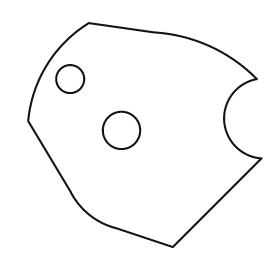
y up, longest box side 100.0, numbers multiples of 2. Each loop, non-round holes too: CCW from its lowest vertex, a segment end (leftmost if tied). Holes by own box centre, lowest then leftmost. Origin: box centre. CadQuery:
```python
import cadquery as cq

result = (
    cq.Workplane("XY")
    .moveTo(12.0, -48.0)
    .lineTo(50.0, -10.0)
    .threePointArc((34.0, 6.0), (48.0, 24.0))
    .threePointArc((28.0, 38.0), (4.0, 44.0))
    .lineTo(-24.0, 48.0)
    .threePointArc((-42.0, 30.0), (-50.0, 6.0))
    .lineTo(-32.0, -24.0)
    .threePointArc((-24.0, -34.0), (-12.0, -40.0))
    .close()
    .moveTo(-10.0, 2.0)
    .circle(8.0)
    .moveTo(-32.0, 24.0)
    .circle(6.0)
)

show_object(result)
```